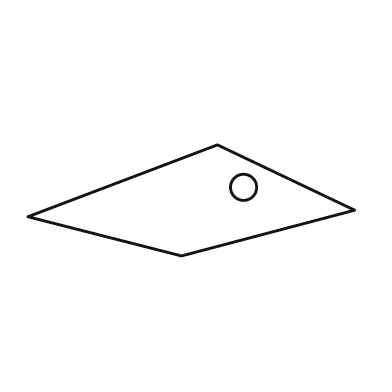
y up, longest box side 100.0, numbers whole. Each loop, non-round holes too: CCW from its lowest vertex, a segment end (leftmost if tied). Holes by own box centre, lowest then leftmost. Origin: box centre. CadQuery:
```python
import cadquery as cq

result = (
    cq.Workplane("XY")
    .moveTo(-3.0, -17.0)
    .lineTo(50.0, -3.0)
    .lineTo(8.0, 17.0)
    .lineTo(-50.0, -5.0)
    .close()
    .moveTo(16.0, 4.0)
    .circle(4.0)
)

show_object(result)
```